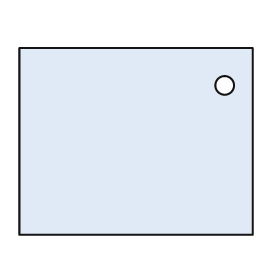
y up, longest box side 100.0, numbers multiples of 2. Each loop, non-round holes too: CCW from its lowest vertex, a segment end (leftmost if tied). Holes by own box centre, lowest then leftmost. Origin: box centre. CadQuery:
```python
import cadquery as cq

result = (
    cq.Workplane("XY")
    .moveTo(-50.0, -40.0)
    .lineTo(50.0, -40.0)
    .lineTo(50.0, 40.0)
    .lineTo(-50.0, 40.0)
    .close()
    .moveTo(38.0, 24.0)
    .circle(4.0)
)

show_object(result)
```